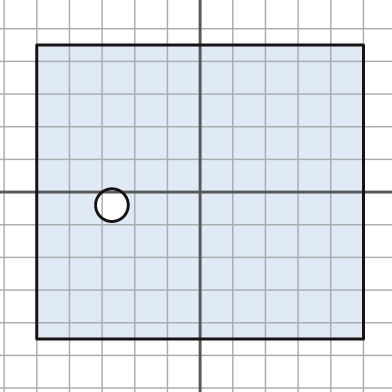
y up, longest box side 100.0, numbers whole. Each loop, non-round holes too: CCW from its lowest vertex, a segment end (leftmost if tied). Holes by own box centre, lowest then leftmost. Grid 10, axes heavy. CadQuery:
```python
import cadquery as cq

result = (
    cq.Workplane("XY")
    .moveTo(-50.0, -45.0)
    .lineTo(50.0, -45.0)
    .lineTo(50.0, 45.0)
    .lineTo(-50.0, 45.0)
    .close()
    .moveTo(-27.0, -4.0)
    .circle(5.0)
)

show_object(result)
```